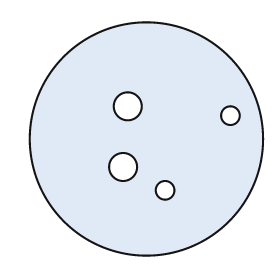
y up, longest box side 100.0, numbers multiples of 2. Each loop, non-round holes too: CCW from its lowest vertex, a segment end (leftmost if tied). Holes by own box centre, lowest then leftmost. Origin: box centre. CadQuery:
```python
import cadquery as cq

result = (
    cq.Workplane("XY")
    .moveTo(0.0, 0.0)
    .circle(50.0)
    .moveTo(8.0, -22.0)
    .circle(4.0)
    .moveTo(-10.0, -12.0)
    .circle(6.0)
    .moveTo(36.0, 10.0)
    .circle(4.0)
    .moveTo(-8.0, 14.0)
    .circle(6.0)
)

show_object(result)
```